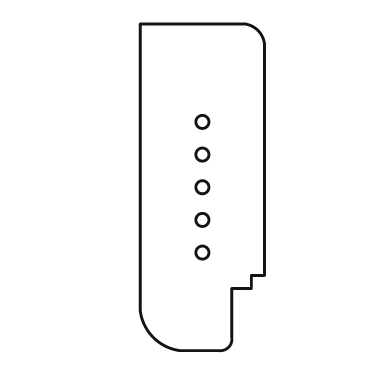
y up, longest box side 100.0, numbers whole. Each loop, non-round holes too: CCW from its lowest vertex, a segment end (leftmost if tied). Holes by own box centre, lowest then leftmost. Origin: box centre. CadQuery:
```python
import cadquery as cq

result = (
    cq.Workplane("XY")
    .moveTo(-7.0, -50.0)
    .lineTo(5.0, -50.0)
    .threePointArc((8.0, -49.0), (9.0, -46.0))
    .lineTo(9.0, -31.0)
    .lineTo(15.0, -31.0)
    .lineTo(15.0, -27.0)
    .lineTo(19.0, -27.0)
    .lineTo(19.0, 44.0)
    .threePointArc((17.0, 48.0), (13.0, 50.0))
    .lineTo(-19.0, 50.0)
    .lineTo(-19.0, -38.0)
    .threePointArc((-15.0, -46.0), (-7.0, -50.0))
    .close()
    .moveTo(0.0, -20.0)
    .circle(2.0)
    .moveTo(0.0, -10.0)
    .circle(2.0)
    .moveTo(0.0, 0.0)
    .circle(2.0)
    .moveTo(0.0, 10.0)
    .circle(2.0)
    .moveTo(0.0, 20.0)
    .circle(2.0)
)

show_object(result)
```